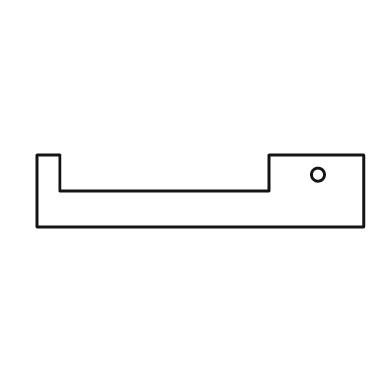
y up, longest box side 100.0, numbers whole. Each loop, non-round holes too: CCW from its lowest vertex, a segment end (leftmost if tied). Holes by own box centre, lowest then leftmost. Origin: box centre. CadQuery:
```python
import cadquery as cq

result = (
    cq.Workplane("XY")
    .moveTo(-50.0, -11.0)
    .lineTo(50.0, -11.0)
    .lineTo(50.0, 11.0)
    .lineTo(21.0, 11.0)
    .lineTo(21.0, 0.0)
    .lineTo(-43.0, 0.0)
    .lineTo(-43.0, 11.0)
    .lineTo(-50.0, 11.0)
    .close()
    .moveTo(36.0, 5.0)
    .circle(2.0)
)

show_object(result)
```